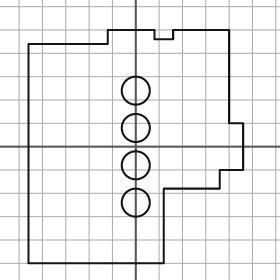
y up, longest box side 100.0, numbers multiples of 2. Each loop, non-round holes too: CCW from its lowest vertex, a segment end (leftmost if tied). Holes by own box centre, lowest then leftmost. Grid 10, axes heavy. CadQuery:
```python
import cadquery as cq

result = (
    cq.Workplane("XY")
    .moveTo(-46.0, -50.0)
    .lineTo(12.0, -50.0)
    .lineTo(12.0, -18.0)
    .lineTo(36.0, -18.0)
    .lineTo(36.0, -10.0)
    .lineTo(46.0, -10.0)
    .lineTo(46.0, 10.0)
    .lineTo(40.0, 10.0)
    .lineTo(40.0, 50.0)
    .lineTo(16.0, 50.0)
    .lineTo(16.0, 46.0)
    .lineTo(8.0, 46.0)
    .lineTo(8.0, 50.0)
    .lineTo(-12.0, 50.0)
    .lineTo(-12.0, 44.0)
    .lineTo(-46.0, 44.0)
    .close()
    .moveTo(0.0, -24.0)
    .circle(6.0)
    .moveTo(0.0, -8.0)
    .circle(6.0)
    .moveTo(0.0, 8.0)
    .circle(6.0)
    .moveTo(0.0, 24.0)
    .circle(6.0)
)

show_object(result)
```